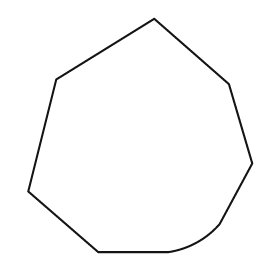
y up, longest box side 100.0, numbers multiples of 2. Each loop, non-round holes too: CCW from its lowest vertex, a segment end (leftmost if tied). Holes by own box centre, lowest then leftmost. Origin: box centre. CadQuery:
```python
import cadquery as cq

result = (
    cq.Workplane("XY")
    .moveTo(-18.0, -50.0)
    .lineTo(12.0, -50.0)
    .threePointArc((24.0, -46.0), (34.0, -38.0))
    .lineTo(48.0, -12.0)
    .lineTo(38.0, 22.0)
    .lineTo(6.0, 50.0)
    .lineTo(-36.0, 24.0)
    .lineTo(-48.0, -24.0)
    .close()
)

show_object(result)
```